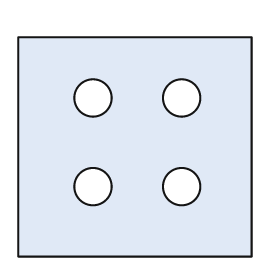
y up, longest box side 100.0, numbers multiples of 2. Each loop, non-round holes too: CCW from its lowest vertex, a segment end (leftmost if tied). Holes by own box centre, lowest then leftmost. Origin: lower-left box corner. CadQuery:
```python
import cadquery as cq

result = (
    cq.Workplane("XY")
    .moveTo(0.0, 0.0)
    .lineTo(100.0, 0.0)
    .lineTo(100.0, 94.0)
    .lineTo(0.0, 94.0)
    .close()
    .moveTo(32.0, 30.0)
    .circle(8.0)
    .moveTo(70.0, 30.0)
    .circle(8.0)
    .moveTo(32.0, 68.0)
    .circle(8.0)
    .moveTo(70.0, 68.0)
    .circle(8.0)
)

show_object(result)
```